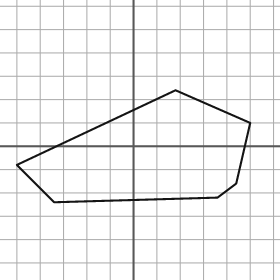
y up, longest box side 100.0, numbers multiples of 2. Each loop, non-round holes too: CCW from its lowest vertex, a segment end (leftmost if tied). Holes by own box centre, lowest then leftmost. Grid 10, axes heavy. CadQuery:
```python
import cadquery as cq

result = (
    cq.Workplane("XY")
    .moveTo(-34.0, -24.0)
    .lineTo(36.0, -22.0)
    .lineTo(44.0, -16.0)
    .lineTo(50.0, 10.0)
    .lineTo(18.0, 24.0)
    .lineTo(-50.0, -8.0)
    .close()
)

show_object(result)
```